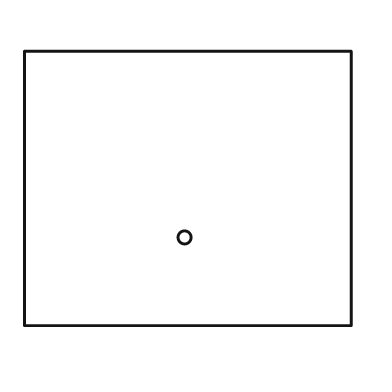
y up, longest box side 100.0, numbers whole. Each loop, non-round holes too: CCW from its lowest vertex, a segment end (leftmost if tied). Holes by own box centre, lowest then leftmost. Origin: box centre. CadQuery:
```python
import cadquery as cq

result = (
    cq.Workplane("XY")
    .moveTo(-50.0, -42.0)
    .lineTo(50.0, -42.0)
    .lineTo(50.0, 42.0)
    .lineTo(-50.0, 42.0)
    .close()
    .moveTo(-1.0, -15.0)
    .circle(2.0)
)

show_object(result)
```